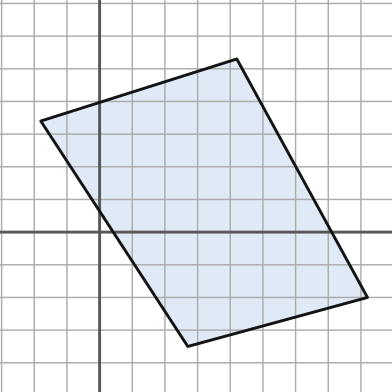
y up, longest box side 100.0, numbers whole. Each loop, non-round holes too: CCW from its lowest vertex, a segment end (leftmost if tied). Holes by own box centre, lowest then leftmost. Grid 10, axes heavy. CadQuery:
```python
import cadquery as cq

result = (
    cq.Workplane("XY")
    .moveTo(27.0, -35.0)
    .lineTo(82.0, -20.0)
    .lineTo(42.0, 53.0)
    .lineTo(-18.0, 34.0)
    .close()
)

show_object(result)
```